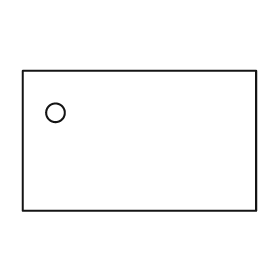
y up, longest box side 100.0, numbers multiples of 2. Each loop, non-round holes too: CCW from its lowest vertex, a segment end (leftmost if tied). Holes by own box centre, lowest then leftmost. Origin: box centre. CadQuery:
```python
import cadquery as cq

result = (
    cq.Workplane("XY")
    .moveTo(-50.0, -30.0)
    .lineTo(50.0, -30.0)
    .lineTo(50.0, 30.0)
    .lineTo(-50.0, 30.0)
    .close()
    .moveTo(-36.0, 12.0)
    .circle(4.0)
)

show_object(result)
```